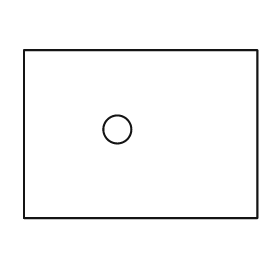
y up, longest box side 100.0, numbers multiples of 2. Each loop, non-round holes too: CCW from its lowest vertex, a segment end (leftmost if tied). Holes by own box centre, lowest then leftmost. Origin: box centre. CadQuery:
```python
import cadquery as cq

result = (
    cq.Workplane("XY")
    .moveTo(-50.0, -36.0)
    .lineTo(50.0, -36.0)
    .lineTo(50.0, 36.0)
    .lineTo(-50.0, 36.0)
    .close()
    .moveTo(-10.0, 2.0)
    .circle(6.0)
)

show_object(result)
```